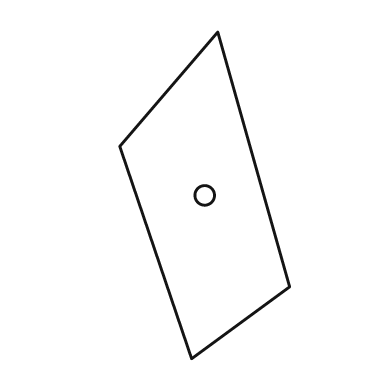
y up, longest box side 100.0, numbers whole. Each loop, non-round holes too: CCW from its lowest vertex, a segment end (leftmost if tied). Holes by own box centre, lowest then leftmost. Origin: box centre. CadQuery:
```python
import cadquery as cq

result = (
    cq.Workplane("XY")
    .moveTo(-4.0, -50.0)
    .lineTo(26.0, -28.0)
    .lineTo(4.0, 50.0)
    .lineTo(-26.0, 15.0)
    .close()
    .moveTo(0.0, 0.0)
    .circle(3.0)
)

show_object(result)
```